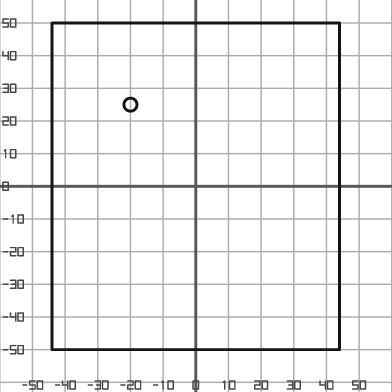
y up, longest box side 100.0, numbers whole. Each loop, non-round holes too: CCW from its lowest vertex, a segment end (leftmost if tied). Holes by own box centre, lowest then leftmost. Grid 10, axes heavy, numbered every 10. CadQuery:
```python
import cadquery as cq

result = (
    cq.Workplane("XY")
    .moveTo(-44.0, -50.0)
    .lineTo(44.0, -50.0)
    .lineTo(44.0, 50.0)
    .lineTo(-44.0, 50.0)
    .close()
    .moveTo(-20.0, 25.0)
    .circle(2.0)
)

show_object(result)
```